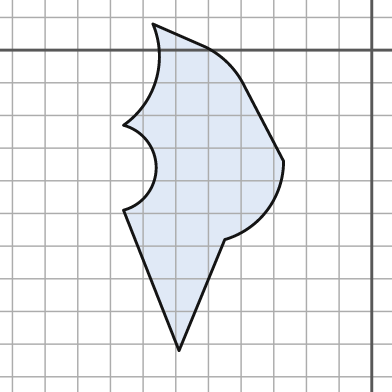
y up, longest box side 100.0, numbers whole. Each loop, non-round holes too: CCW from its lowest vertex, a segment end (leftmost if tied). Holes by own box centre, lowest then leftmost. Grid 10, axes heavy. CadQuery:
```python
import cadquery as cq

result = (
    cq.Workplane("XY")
    .moveTo(-59.0, -92.0)
    .lineTo(-45.0, -58.0)
    .threePointArc((-32.0, -49.0), (-27.0, -34.0))
    .lineTo(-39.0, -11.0)
    .threePointArc((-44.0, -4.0), (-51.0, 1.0))
    .lineTo(-67.0, 8.0)
    .threePointArc((-66.0, -9.0), (-76.0, -23.0))
    .threePointArc((-66.0, -36.0), (-76.0, -49.0))
    .close()
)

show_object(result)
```